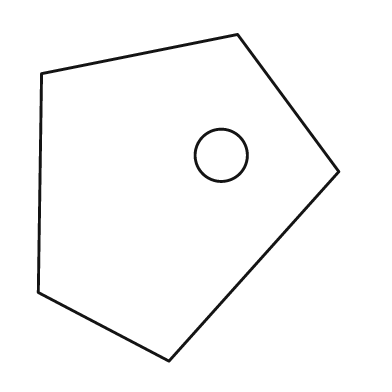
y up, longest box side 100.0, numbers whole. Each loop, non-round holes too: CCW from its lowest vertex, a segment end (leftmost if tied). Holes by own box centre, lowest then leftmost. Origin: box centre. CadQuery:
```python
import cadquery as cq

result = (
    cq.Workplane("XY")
    .moveTo(-6.0, -50.0)
    .lineTo(46.0, 8.0)
    .lineTo(15.0, 50.0)
    .lineTo(-45.0, 38.0)
    .lineTo(-46.0, -29.0)
    .close()
    .moveTo(10.0, 13.0)
    .circle(8.0)
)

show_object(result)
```